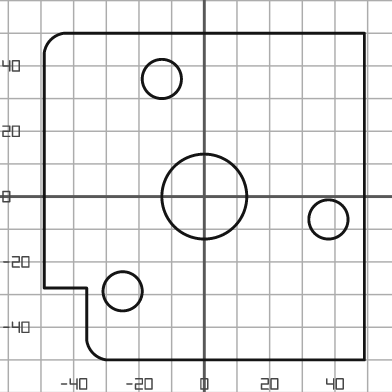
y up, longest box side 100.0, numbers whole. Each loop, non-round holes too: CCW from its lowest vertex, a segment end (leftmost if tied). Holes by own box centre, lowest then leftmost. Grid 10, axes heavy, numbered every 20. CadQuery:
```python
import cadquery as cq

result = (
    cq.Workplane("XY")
    .moveTo(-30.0, -50.0)
    .lineTo(49.0, -50.0)
    .lineTo(49.0, 50.0)
    .lineTo(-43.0, 50.0)
    .threePointArc((-47.0, 48.0), (-49.0, 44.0))
    .lineTo(-49.0, -28.0)
    .lineTo(-36.0, -28.0)
    .lineTo(-36.0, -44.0)
    .threePointArc((-34.0, -48.0), (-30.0, -50.0))
    .close()
    .moveTo(-25.0, -29.0)
    .circle(6.0)
    .moveTo(38.0, -7.0)
    .circle(6.0)
    .moveTo(0.0, 0.0)
    .circle(13.0)
    .moveTo(-13.0, 36.0)
    .circle(6.0)
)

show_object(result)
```